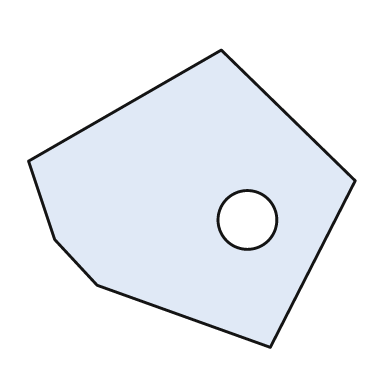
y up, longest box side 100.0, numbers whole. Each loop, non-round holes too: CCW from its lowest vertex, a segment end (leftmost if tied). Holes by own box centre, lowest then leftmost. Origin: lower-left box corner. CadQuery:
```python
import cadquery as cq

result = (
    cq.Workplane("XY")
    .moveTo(74.0, 0.0)
    .lineTo(100.0, 51.0)
    .lineTo(59.0, 91.0)
    .lineTo(0.0, 57.0)
    .lineTo(8.0, 33.0)
    .lineTo(21.0, 19.0)
    .close()
    .moveTo(67.0, 39.0)
    .circle(9.0)
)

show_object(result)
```